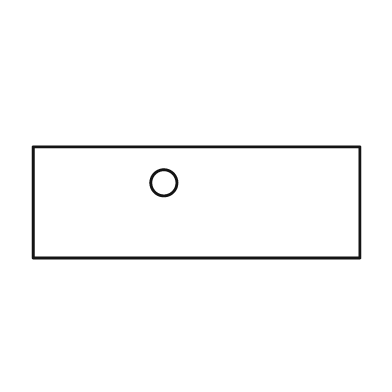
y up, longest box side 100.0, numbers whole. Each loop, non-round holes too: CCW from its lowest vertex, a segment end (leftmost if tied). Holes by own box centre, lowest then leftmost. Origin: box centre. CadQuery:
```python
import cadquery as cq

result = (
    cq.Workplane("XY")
    .moveTo(-50.0, -17.0)
    .lineTo(50.0, -17.0)
    .lineTo(50.0, 17.0)
    .lineTo(-50.0, 17.0)
    .close()
    .moveTo(-10.0, 6.0)
    .circle(4.0)
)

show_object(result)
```